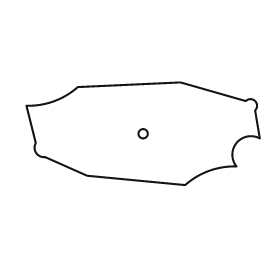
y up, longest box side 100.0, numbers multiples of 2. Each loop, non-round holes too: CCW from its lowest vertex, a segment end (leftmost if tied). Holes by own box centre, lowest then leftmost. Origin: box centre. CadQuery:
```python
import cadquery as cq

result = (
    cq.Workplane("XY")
    .moveTo(18.0, -22.0)
    .threePointArc((28.0, -16.0), (40.0, -14.0))
    .threePointArc((40.0, -4.0), (50.0, -2.0))
    .lineTo(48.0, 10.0)
    .threePointArc((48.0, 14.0), (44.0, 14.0))
    .lineTo(16.0, 22.0)
    .lineTo(-28.0, 20.0)
    .threePointArc((-38.0, 14.0), (-50.0, 12.0))
    .lineTo(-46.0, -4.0)
    .threePointArc((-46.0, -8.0), (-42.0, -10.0))
    .lineTo(-24.0, -18.0)
    .close()
    .moveTo(0.0, 0.0)
    .circle(2.0)
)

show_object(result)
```